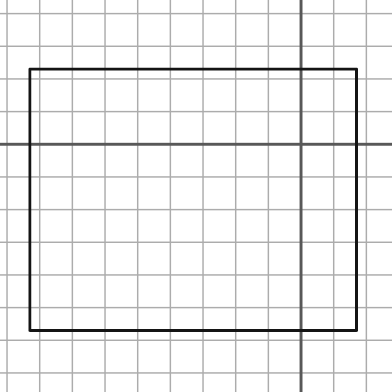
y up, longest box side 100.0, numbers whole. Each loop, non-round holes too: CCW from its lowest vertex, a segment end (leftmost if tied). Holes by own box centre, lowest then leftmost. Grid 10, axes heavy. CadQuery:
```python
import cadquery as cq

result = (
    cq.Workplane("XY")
    .moveTo(-83.0, -57.0)
    .lineTo(17.0, -57.0)
    .lineTo(17.0, 23.0)
    .lineTo(-83.0, 23.0)
    .close()
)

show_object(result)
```